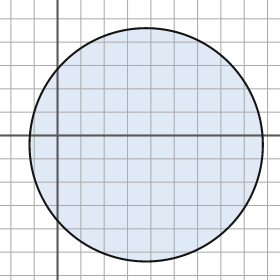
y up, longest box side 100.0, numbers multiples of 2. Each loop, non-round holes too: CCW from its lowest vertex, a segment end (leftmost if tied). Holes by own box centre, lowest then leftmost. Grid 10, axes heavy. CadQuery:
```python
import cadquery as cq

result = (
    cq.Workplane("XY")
    .moveTo(38.0, -4.0)
    .circle(50.0)
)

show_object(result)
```